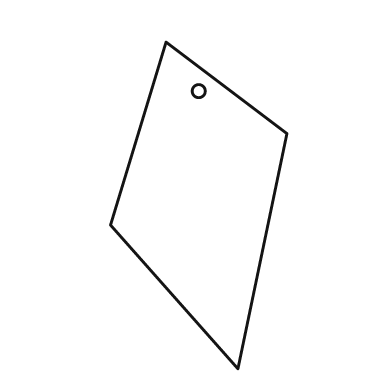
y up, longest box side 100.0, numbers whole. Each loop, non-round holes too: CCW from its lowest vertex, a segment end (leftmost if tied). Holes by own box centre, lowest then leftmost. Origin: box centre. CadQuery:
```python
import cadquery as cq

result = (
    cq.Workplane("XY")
    .moveTo(12.0, -50.0)
    .lineTo(27.0, 22.0)
    .lineTo(-10.0, 50.0)
    .lineTo(-27.0, -6.0)
    .close()
    .moveTo(0.0, 35.0)
    .circle(2.0)
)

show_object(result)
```